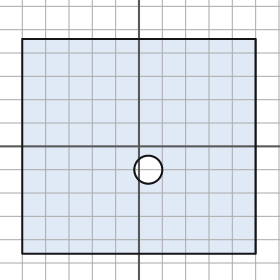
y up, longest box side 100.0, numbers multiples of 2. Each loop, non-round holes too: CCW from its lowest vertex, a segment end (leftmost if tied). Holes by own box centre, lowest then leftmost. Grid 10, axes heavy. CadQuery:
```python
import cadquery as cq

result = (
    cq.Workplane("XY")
    .moveTo(-50.0, -46.0)
    .lineTo(50.0, -46.0)
    .lineTo(50.0, 46.0)
    .lineTo(-50.0, 46.0)
    .close()
    .moveTo(4.0, -10.0)
    .circle(6.0)
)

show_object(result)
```